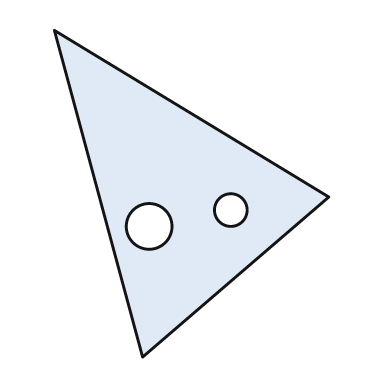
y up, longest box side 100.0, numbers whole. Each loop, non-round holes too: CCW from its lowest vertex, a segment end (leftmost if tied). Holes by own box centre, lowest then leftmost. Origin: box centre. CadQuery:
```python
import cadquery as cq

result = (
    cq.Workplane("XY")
    .moveTo(-15.0, -50.0)
    .lineTo(42.0, -1.0)
    .lineTo(-42.0, 50.0)
    .close()
    .moveTo(-13.0, -10.0)
    .circle(7.0)
    .moveTo(12.0, -5.0)
    .circle(5.0)
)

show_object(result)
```